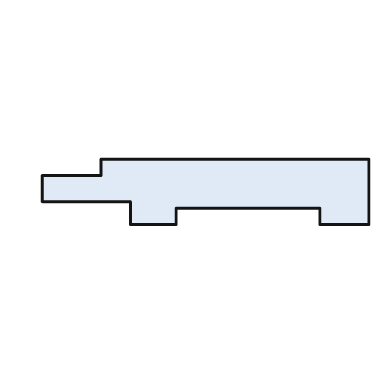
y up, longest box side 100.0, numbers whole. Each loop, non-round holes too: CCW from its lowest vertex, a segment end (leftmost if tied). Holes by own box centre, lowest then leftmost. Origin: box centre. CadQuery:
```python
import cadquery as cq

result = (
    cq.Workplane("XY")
    .moveTo(-23.0, -10.0)
    .lineTo(-9.0, -10.0)
    .lineTo(-9.0, -5.0)
    .lineTo(35.0, -5.0)
    .lineTo(35.0, -10.0)
    .lineTo(50.0, -10.0)
    .lineTo(50.0, 10.0)
    .lineTo(-32.0, 10.0)
    .lineTo(-32.0, 5.0)
    .lineTo(-50.0, 5.0)
    .lineTo(-50.0, -3.0)
    .lineTo(-23.0, -3.0)
    .close()
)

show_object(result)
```